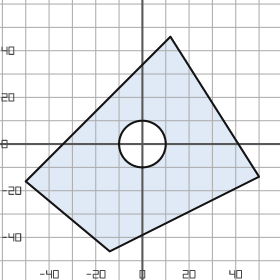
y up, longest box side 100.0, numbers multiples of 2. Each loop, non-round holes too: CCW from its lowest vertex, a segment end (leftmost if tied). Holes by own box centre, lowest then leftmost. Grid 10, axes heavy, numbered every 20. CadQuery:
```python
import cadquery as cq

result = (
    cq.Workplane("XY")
    .moveTo(-14.0, -46.0)
    .lineTo(50.0, -14.0)
    .lineTo(12.0, 46.0)
    .lineTo(-50.0, -16.0)
    .close()
    .moveTo(0.0, 0.0)
    .circle(10.0)
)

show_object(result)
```